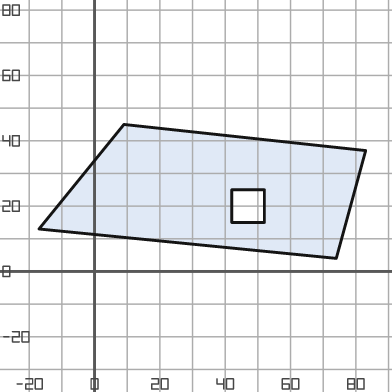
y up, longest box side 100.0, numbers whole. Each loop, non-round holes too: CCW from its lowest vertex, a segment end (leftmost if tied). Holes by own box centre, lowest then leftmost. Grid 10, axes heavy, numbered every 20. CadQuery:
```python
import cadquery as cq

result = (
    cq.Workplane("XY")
    .moveTo(74.0, 4.0)
    .lineTo(83.0, 37.0)
    .lineTo(9.0, 45.0)
    .lineTo(-17.0, 13.0)
    .close()
    .moveTo(42.0, 15.0)
    .lineTo(52.0, 15.0)
    .lineTo(52.0, 25.0)
    .lineTo(42.0, 25.0)
    .close()
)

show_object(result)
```